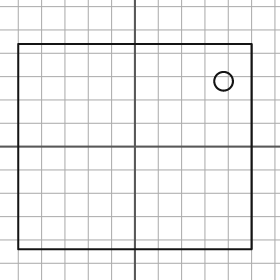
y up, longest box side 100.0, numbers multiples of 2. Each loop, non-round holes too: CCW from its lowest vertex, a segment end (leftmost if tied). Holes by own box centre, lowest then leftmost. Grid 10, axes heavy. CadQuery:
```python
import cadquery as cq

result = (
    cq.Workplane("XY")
    .moveTo(-50.0, -44.0)
    .lineTo(50.0, -44.0)
    .lineTo(50.0, 44.0)
    .lineTo(-50.0, 44.0)
    .close()
    .moveTo(38.0, 28.0)
    .circle(4.0)
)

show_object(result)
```